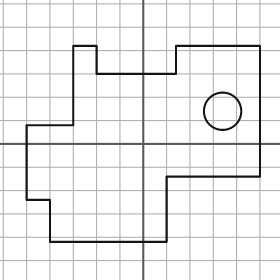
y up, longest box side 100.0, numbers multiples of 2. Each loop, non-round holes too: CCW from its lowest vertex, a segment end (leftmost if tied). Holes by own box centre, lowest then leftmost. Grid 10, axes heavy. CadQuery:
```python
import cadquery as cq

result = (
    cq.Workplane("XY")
    .moveTo(-40.0, -42.0)
    .lineTo(10.0, -42.0)
    .lineTo(10.0, -14.0)
    .lineTo(50.0, -14.0)
    .lineTo(50.0, 42.0)
    .lineTo(14.0, 42.0)
    .lineTo(14.0, 30.0)
    .lineTo(-20.0, 30.0)
    .lineTo(-20.0, 42.0)
    .lineTo(-30.0, 42.0)
    .lineTo(-30.0, 8.0)
    .lineTo(-50.0, 8.0)
    .lineTo(-50.0, -24.0)
    .lineTo(-40.0, -24.0)
    .close()
    .moveTo(34.0, 14.0)
    .circle(8.0)
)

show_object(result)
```